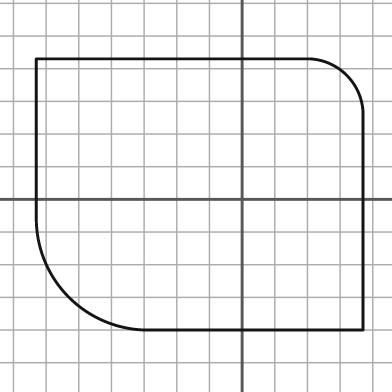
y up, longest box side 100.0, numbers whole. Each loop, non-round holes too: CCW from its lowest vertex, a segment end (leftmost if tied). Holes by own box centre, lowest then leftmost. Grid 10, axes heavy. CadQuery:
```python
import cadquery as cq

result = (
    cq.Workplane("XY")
    .moveTo(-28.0, -40.0)
    .lineTo(37.0, -40.0)
    .lineTo(37.0, 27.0)
    .threePointArc((32.0, 38.0), (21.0, 43.0))
    .lineTo(-63.0, 43.0)
    .lineTo(-63.0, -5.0)
    .threePointArc((-53.0, -30.0), (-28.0, -40.0))
    .close()
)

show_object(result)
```